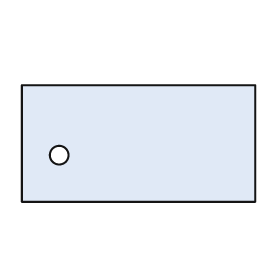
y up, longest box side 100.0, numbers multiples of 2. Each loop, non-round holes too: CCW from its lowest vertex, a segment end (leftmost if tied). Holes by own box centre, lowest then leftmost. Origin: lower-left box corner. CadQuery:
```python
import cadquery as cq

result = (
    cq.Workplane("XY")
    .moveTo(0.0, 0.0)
    .lineTo(100.0, 0.0)
    .lineTo(100.0, 50.0)
    .lineTo(0.0, 50.0)
    .close()
    .moveTo(16.0, 20.0)
    .circle(4.0)
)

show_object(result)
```